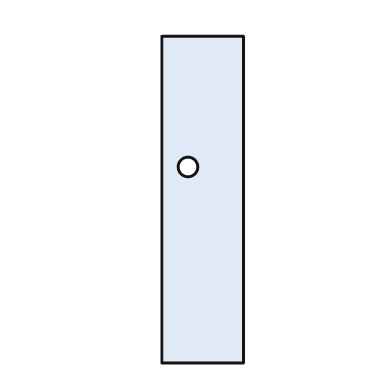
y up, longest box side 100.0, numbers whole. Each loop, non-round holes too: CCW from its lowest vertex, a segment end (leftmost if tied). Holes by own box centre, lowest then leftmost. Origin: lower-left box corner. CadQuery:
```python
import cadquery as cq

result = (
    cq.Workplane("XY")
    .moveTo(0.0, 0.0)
    .lineTo(25.0, 0.0)
    .lineTo(25.0, 100.0)
    .lineTo(0.0, 100.0)
    .close()
    .moveTo(8.0, 60.0)
    .circle(3.0)
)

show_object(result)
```